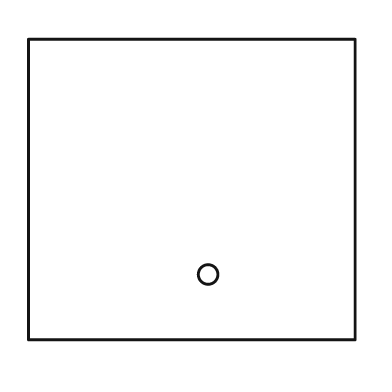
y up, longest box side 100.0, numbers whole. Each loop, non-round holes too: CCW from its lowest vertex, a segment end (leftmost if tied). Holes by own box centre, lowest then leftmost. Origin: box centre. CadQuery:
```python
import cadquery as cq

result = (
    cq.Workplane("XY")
    .moveTo(-50.0, -46.0)
    .lineTo(50.0, -46.0)
    .lineTo(50.0, 46.0)
    .lineTo(-50.0, 46.0)
    .close()
    .moveTo(5.0, -26.0)
    .circle(3.0)
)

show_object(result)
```